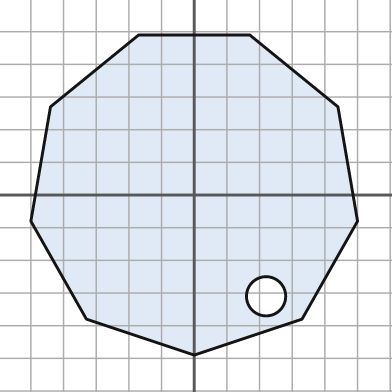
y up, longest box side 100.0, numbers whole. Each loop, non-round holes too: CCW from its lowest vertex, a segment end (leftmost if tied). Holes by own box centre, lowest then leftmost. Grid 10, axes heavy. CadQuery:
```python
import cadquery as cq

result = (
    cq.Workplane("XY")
    .moveTo(0.0, -49.0)
    .lineTo(33.0, -38.0)
    .lineTo(50.0, -8.0)
    .lineTo(44.0, 27.0)
    .lineTo(17.0, 49.0)
    .lineTo(-17.0, 49.0)
    .lineTo(-44.0, 27.0)
    .lineTo(-50.0, -8.0)
    .lineTo(-33.0, -38.0)
    .close()
    .moveTo(22.0, -31.0)
    .circle(6.0)
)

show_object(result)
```